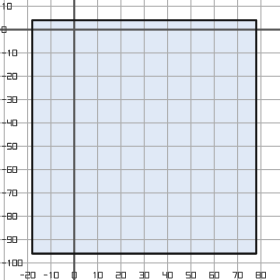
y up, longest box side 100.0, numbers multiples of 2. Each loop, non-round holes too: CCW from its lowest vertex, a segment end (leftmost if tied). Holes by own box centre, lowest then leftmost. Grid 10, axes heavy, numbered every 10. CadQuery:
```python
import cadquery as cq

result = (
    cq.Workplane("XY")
    .moveTo(-18.0, -96.0)
    .lineTo(78.0, -96.0)
    .lineTo(78.0, 4.0)
    .lineTo(-18.0, 4.0)
    .close()
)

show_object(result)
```